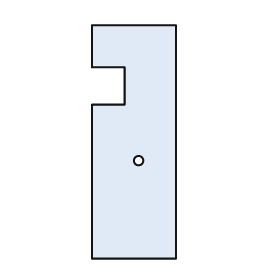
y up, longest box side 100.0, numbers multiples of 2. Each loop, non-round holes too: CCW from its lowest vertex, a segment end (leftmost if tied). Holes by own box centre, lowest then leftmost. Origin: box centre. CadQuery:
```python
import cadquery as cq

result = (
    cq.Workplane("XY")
    .moveTo(-18.0, -50.0)
    .lineTo(18.0, -50.0)
    .lineTo(18.0, 50.0)
    .lineTo(-18.0, 50.0)
    .lineTo(-18.0, 32.0)
    .lineTo(-4.0, 32.0)
    .lineTo(-4.0, 16.0)
    .lineTo(-18.0, 16.0)
    .close()
    .moveTo(2.0, -8.0)
    .circle(2.0)
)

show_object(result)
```